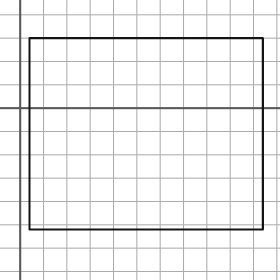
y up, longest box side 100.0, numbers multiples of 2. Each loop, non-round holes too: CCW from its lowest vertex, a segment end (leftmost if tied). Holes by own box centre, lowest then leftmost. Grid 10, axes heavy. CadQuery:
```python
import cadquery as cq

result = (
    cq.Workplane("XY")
    .moveTo(4.0, -52.0)
    .lineTo(104.0, -52.0)
    .lineTo(104.0, 30.0)
    .lineTo(4.0, 30.0)
    .close()
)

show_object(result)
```